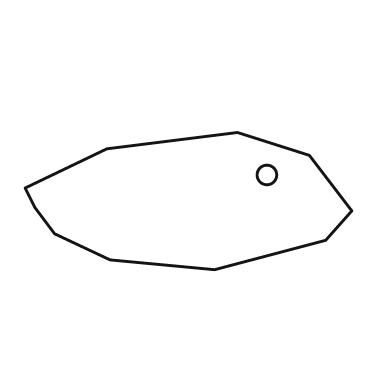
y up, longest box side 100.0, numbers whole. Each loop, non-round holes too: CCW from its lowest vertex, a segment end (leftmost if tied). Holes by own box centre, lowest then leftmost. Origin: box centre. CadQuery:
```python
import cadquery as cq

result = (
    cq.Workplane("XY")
    .moveTo(8.0, -21.0)
    .lineTo(42.0, -12.0)
    .lineTo(50.0, -3.0)
    .lineTo(37.0, 14.0)
    .lineTo(15.0, 21.0)
    .lineTo(-25.0, 16.0)
    .lineTo(-50.0, 4.0)
    .lineTo(-47.0, -2.0)
    .lineTo(-41.0, -10.0)
    .lineTo(-24.0, -18.0)
    .close()
    .moveTo(24.0, 8.0)
    .circle(3.0)
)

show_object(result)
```